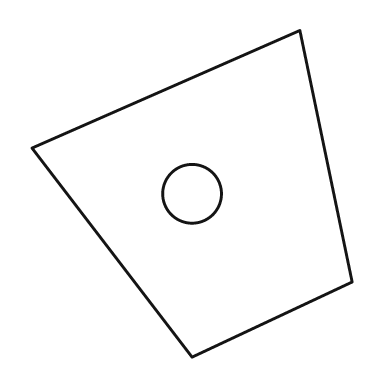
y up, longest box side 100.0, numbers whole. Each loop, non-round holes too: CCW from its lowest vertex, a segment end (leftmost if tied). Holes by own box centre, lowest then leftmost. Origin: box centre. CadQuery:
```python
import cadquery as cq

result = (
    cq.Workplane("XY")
    .moveTo(0.0, -50.0)
    .lineTo(49.0, -27.0)
    .lineTo(33.0, 50.0)
    .lineTo(-49.0, 14.0)
    .close()
    .moveTo(0.0, 0.0)
    .circle(9.0)
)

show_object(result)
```